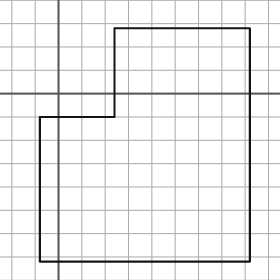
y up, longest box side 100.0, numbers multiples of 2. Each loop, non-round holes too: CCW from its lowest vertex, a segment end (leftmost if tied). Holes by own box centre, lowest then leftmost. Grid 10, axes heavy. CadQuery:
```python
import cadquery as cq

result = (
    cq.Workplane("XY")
    .moveTo(-8.0, -72.0)
    .lineTo(82.0, -72.0)
    .lineTo(82.0, 28.0)
    .lineTo(24.0, 28.0)
    .lineTo(24.0, -10.0)
    .lineTo(-8.0, -10.0)
    .close()
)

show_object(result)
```